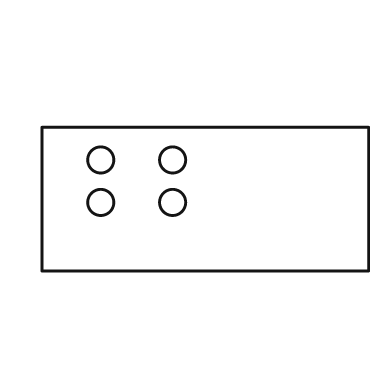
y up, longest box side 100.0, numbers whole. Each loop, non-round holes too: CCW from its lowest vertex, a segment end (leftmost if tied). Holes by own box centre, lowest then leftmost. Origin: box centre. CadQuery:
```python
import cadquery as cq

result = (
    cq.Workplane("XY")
    .moveTo(-50.0, -22.0)
    .lineTo(50.0, -22.0)
    .lineTo(50.0, 22.0)
    .lineTo(-50.0, 22.0)
    .close()
    .moveTo(-32.0, -1.0)
    .circle(4.0)
    .moveTo(-10.0, -1.0)
    .circle(4.0)
    .moveTo(-32.0, 12.0)
    .circle(4.0)
    .moveTo(-10.0, 12.0)
    .circle(4.0)
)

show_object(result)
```